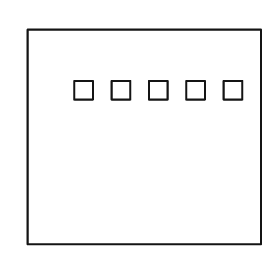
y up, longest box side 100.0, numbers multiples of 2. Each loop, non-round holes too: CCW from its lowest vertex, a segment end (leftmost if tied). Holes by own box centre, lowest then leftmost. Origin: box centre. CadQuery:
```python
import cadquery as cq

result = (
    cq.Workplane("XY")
    .moveTo(-50.0, -46.0)
    .lineTo(50.0, -46.0)
    .lineTo(50.0, 46.0)
    .lineTo(-50.0, 46.0)
    .close()
    .moveTo(-30.0, 16.0)
    .lineTo(-22.0, 16.0)
    .lineTo(-22.0, 24.0)
    .lineTo(-30.0, 24.0)
    .close()
    .moveTo(-14.0, 16.0)
    .lineTo(-6.0, 16.0)
    .lineTo(-6.0, 24.0)
    .lineTo(-14.0, 24.0)
    .close()
    .moveTo(2.0, 16.0)
    .lineTo(10.0, 16.0)
    .lineTo(10.0, 24.0)
    .lineTo(2.0, 24.0)
    .close()
    .moveTo(18.0, 16.0)
    .lineTo(26.0, 16.0)
    .lineTo(26.0, 24.0)
    .lineTo(18.0, 24.0)
    .close()
    .moveTo(34.0, 16.0)
    .lineTo(42.0, 16.0)
    .lineTo(42.0, 24.0)
    .lineTo(34.0, 24.0)
    .close()
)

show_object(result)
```